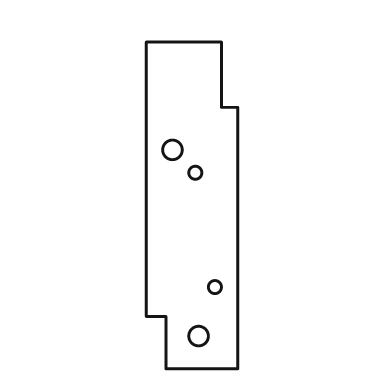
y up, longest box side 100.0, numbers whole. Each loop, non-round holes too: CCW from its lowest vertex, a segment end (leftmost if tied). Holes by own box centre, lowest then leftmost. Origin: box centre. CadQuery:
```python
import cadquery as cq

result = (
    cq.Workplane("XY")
    .moveTo(-8.0, -50.0)
    .lineTo(14.0, -50.0)
    .lineTo(14.0, 30.0)
    .lineTo(9.0, 30.0)
    .lineTo(9.0, 50.0)
    .lineTo(-14.0, 50.0)
    .lineTo(-14.0, -34.0)
    .lineTo(-8.0, -34.0)
    .close()
    .moveTo(2.0, -40.0)
    .circle(3.0)
    .moveTo(7.0, -25.0)
    .circle(2.0)
    .moveTo(1.0, 10.0)
    .circle(2.0)
    .moveTo(-6.0, 17.0)
    .circle(3.0)
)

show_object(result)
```